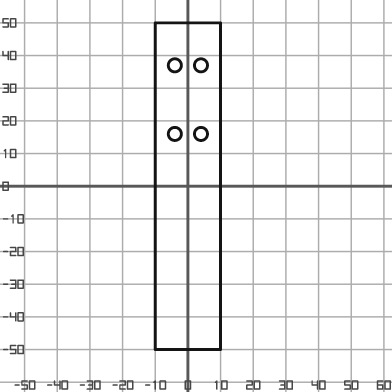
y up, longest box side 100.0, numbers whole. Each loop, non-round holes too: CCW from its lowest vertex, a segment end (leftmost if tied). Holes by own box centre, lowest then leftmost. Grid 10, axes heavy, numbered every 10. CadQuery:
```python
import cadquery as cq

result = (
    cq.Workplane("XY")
    .moveTo(-10.0, -50.0)
    .lineTo(10.0, -50.0)
    .lineTo(10.0, 50.0)
    .lineTo(-10.0, 50.0)
    .close()
    .moveTo(-4.0, 16.0)
    .circle(2.0)
    .moveTo(4.0, 16.0)
    .circle(2.0)
    .moveTo(-4.0, 37.0)
    .circle(2.0)
    .moveTo(4.0, 37.0)
    .circle(2.0)
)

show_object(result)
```